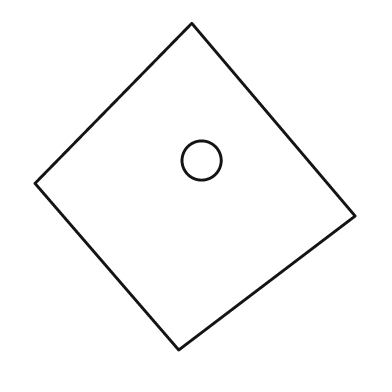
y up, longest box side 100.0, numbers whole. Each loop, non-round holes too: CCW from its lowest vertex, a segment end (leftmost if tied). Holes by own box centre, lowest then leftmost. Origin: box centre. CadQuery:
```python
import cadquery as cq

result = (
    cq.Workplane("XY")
    .moveTo(-5.0, -50.0)
    .lineTo(49.0, -9.0)
    .lineTo(-1.0, 50.0)
    .lineTo(-49.0, 1.0)
    .close()
    .moveTo(2.0, 8.0)
    .circle(6.0)
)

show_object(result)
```